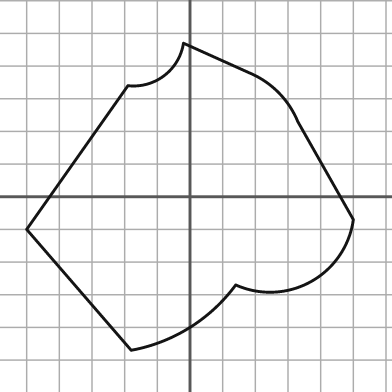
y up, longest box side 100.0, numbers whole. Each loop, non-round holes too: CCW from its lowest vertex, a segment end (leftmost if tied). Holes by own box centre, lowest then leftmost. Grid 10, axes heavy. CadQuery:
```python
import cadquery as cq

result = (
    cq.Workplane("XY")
    .moveTo(-18.0, -47.0)
    .threePointArc((0.0, -40.0), (14.0, -27.0))
    .threePointArc((37.0, -26.0), (50.0, -7.0))
    .lineTo(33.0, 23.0)
    .threePointArc((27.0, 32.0), (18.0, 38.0))
    .lineTo(-2.0, 47.0)
    .threePointArc((-8.0, 37.0), (-19.0, 34.0))
    .lineTo(-50.0, -10.0)
    .close()
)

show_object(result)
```